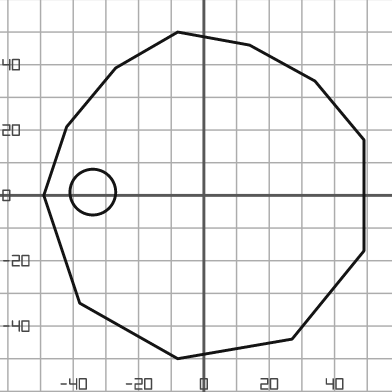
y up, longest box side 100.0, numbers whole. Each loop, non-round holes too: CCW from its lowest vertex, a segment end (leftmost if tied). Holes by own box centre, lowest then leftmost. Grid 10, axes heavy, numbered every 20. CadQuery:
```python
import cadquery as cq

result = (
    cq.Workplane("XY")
    .moveTo(-8.0, -50.0)
    .lineTo(27.0, -44.0)
    .lineTo(49.0, -17.0)
    .lineTo(49.0, 17.0)
    .lineTo(34.0, 35.0)
    .lineTo(14.0, 46.0)
    .lineTo(-8.0, 50.0)
    .lineTo(-27.0, 39.0)
    .lineTo(-42.0, 21.0)
    .lineTo(-49.0, 0.0)
    .lineTo(-38.0, -33.0)
    .close()
    .moveTo(-34.0, 1.0)
    .circle(7.0)
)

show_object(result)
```